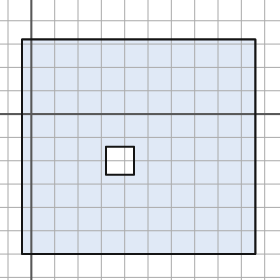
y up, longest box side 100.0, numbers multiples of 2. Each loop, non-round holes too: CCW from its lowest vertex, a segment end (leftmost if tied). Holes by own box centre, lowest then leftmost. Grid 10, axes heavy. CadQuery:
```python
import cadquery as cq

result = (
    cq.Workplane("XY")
    .moveTo(-4.0, -60.0)
    .lineTo(96.0, -60.0)
    .lineTo(96.0, 32.0)
    .lineTo(-4.0, 32.0)
    .close()
    .moveTo(32.0, -26.0)
    .lineTo(44.0, -26.0)
    .lineTo(44.0, -14.0)
    .lineTo(32.0, -14.0)
    .close()
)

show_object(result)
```